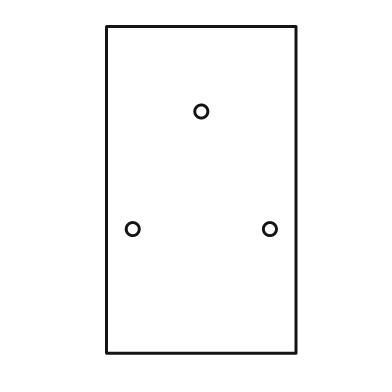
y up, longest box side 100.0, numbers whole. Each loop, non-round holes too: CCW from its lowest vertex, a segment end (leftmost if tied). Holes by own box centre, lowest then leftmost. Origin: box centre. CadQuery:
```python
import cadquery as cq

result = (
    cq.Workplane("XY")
    .moveTo(-29.0, -50.0)
    .lineTo(29.0, -50.0)
    .lineTo(29.0, 50.0)
    .lineTo(-29.0, 50.0)
    .close()
    .moveTo(-21.0, -12.0)
    .circle(2.0)
    .moveTo(21.0, -12.0)
    .circle(2.0)
    .moveTo(0.0, 24.0)
    .circle(2.0)
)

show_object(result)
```